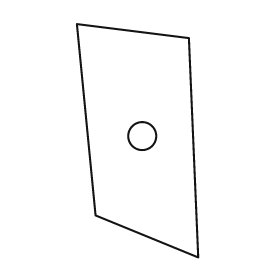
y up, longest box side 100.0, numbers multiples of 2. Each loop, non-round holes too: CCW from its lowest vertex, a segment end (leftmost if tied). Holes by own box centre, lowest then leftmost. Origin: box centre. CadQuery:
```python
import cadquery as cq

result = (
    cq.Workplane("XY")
    .moveTo(26.0, -50.0)
    .lineTo(22.0, 44.0)
    .lineTo(-26.0, 50.0)
    .lineTo(-18.0, -32.0)
    .close()
    .moveTo(2.0, 2.0)
    .circle(6.0)
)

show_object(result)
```